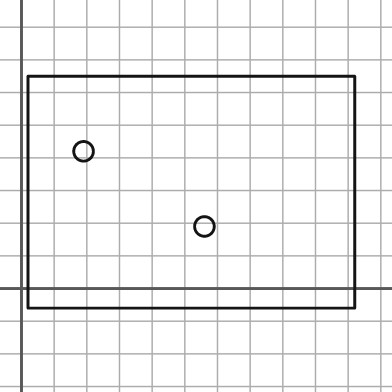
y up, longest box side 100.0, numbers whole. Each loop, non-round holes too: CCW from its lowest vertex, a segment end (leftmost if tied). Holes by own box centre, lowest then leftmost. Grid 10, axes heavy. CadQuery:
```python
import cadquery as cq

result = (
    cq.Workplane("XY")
    .moveTo(2.0, -6.0)
    .lineTo(102.0, -6.0)
    .lineTo(102.0, 65.0)
    .lineTo(2.0, 65.0)
    .close()
    .moveTo(56.0, 19.0)
    .circle(3.0)
    .moveTo(19.0, 42.0)
    .circle(3.0)
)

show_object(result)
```